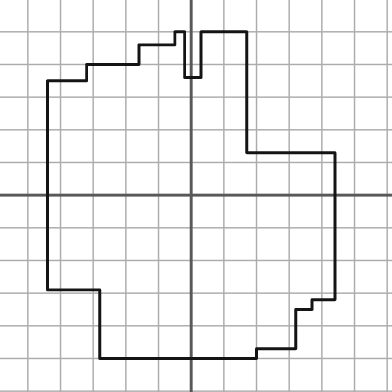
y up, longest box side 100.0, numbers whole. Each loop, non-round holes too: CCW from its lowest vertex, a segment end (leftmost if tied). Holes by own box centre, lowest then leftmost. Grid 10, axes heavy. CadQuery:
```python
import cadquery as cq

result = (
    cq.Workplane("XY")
    .moveTo(-28.0, -50.0)
    .lineTo(20.0, -50.0)
    .lineTo(20.0, -47.0)
    .lineTo(32.0, -47.0)
    .lineTo(32.0, -35.0)
    .lineTo(37.0, -35.0)
    .lineTo(37.0, -32.0)
    .lineTo(44.0, -32.0)
    .lineTo(44.0, 13.0)
    .lineTo(17.0, 13.0)
    .lineTo(17.0, 50.0)
    .lineTo(3.0, 50.0)
    .lineTo(3.0, 36.0)
    .lineTo(-2.0, 36.0)
    .lineTo(-2.0, 50.0)
    .lineTo(-5.0, 50.0)
    .lineTo(-5.0, 46.0)
    .lineTo(-16.0, 46.0)
    .lineTo(-16.0, 40.0)
    .lineTo(-32.0, 40.0)
    .lineTo(-32.0, 35.0)
    .lineTo(-44.0, 35.0)
    .lineTo(-44.0, -29.0)
    .lineTo(-28.0, -29.0)
    .close()
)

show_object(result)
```